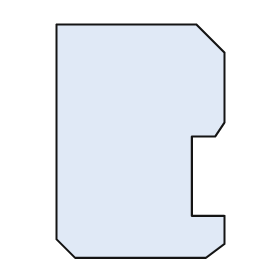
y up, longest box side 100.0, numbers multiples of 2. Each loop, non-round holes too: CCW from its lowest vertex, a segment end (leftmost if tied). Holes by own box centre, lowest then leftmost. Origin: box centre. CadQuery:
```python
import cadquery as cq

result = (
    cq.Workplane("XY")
    .moveTo(-28.0, -50.0)
    .lineTo(28.0, -50.0)
    .lineTo(36.0, -44.0)
    .lineTo(36.0, -32.0)
    .lineTo(22.0, -32.0)
    .lineTo(22.0, 2.0)
    .lineTo(32.0, 2.0)
    .lineTo(36.0, 8.0)
    .lineTo(36.0, 38.0)
    .lineTo(24.0, 50.0)
    .lineTo(-36.0, 50.0)
    .lineTo(-36.0, -42.0)
    .close()
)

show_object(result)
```